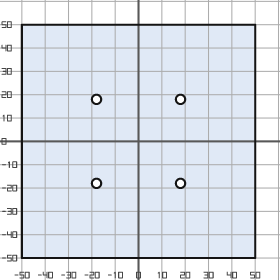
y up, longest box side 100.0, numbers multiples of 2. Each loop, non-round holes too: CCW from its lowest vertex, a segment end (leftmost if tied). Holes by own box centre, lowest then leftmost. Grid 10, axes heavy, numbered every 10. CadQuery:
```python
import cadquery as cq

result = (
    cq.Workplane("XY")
    .moveTo(-50.0, -50.0)
    .lineTo(50.0, -50.0)
    .lineTo(50.0, 50.0)
    .lineTo(-50.0, 50.0)
    .close()
    .moveTo(-18.0, -18.0)
    .circle(2.0)
    .moveTo(18.0, -18.0)
    .circle(2.0)
    .moveTo(-18.0, 18.0)
    .circle(2.0)
    .moveTo(18.0, 18.0)
    .circle(2.0)
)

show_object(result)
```